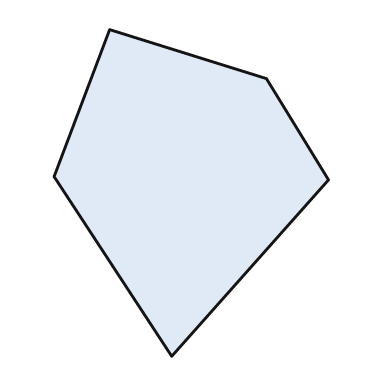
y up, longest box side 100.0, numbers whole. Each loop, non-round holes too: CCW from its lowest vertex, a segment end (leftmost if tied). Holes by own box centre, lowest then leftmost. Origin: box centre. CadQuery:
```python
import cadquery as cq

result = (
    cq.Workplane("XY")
    .moveTo(-6.0, -50.0)
    .lineTo(42.0, 4.0)
    .lineTo(23.0, 35.0)
    .lineTo(-25.0, 50.0)
    .lineTo(-42.0, 5.0)
    .close()
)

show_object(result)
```